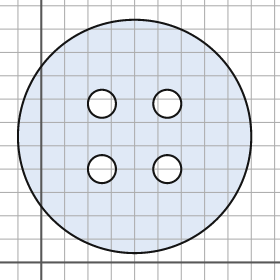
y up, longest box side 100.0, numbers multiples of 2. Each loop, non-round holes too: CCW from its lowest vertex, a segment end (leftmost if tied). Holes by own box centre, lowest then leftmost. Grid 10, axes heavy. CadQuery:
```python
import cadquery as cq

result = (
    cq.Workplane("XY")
    .moveTo(40.0, 54.0)
    .circle(50.0)
    .moveTo(26.0, 40.0)
    .circle(6.0)
    .moveTo(54.0, 40.0)
    .circle(6.0)
    .moveTo(26.0, 68.0)
    .circle(6.0)
    .moveTo(54.0, 68.0)
    .circle(6.0)
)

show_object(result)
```